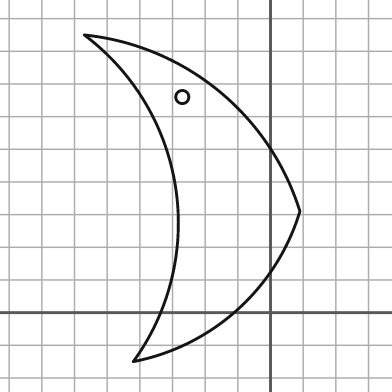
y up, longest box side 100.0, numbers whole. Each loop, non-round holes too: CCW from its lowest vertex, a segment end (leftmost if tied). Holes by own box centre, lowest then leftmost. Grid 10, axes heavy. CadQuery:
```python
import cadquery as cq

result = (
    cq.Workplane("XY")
    .moveTo(-42.0, -15.0)
    .threePointArc((-10.0, 1.0), (9.0, 31.0))
    .threePointArc((-16.0, 68.0), (-57.0, 85.0))
    .threePointArc((-29.0, 38.0), (-42.0, -15.0))
    .close()
    .moveTo(-27.0, 66.0)
    .circle(2.0)
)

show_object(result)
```